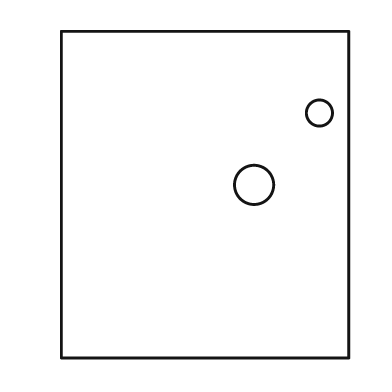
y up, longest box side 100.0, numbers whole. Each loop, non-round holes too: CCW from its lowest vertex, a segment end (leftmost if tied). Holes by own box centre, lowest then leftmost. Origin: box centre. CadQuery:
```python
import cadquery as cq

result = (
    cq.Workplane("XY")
    .moveTo(-44.0, -50.0)
    .lineTo(44.0, -50.0)
    .lineTo(44.0, 50.0)
    .lineTo(-44.0, 50.0)
    .close()
    .moveTo(15.0, 3.0)
    .circle(6.0)
    .moveTo(35.0, 25.0)
    .circle(4.0)
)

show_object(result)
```